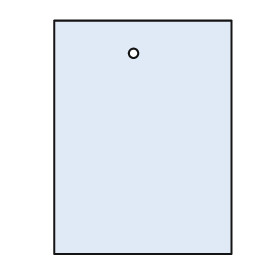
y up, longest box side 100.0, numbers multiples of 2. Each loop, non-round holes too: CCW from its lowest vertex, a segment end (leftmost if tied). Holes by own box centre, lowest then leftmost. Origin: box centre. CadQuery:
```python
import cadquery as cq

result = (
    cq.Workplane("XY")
    .moveTo(-38.0, -50.0)
    .lineTo(38.0, -50.0)
    .lineTo(38.0, 50.0)
    .lineTo(-38.0, 50.0)
    .close()
    .moveTo(-4.0, 36.0)
    .circle(2.0)
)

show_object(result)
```